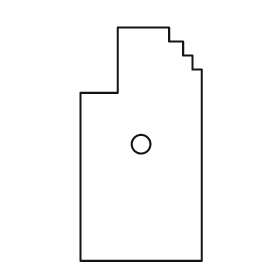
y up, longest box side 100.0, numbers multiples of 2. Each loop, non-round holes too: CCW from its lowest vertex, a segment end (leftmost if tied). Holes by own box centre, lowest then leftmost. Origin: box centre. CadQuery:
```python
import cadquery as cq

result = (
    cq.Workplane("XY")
    .moveTo(-26.0, -50.0)
    .lineTo(26.0, -50.0)
    .lineTo(26.0, 32.0)
    .lineTo(22.0, 32.0)
    .lineTo(22.0, 38.0)
    .lineTo(18.0, 38.0)
    .lineTo(18.0, 44.0)
    .lineTo(12.0, 44.0)
    .lineTo(12.0, 50.0)
    .lineTo(-10.0, 50.0)
    .lineTo(-10.0, 22.0)
    .lineTo(-26.0, 22.0)
    .close()
    .moveTo(0.0, 0.0)
    .circle(4.0)
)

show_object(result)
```